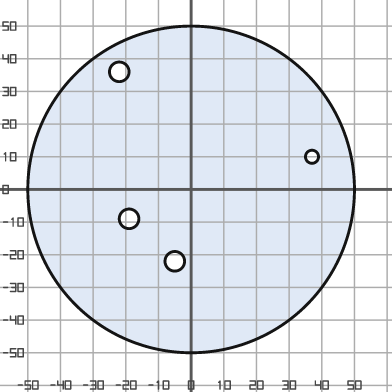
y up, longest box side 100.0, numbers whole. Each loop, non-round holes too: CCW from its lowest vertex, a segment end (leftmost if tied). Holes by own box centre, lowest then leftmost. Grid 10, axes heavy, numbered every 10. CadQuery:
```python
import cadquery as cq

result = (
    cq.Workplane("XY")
    .moveTo(0.0, 0.0)
    .circle(50.0)
    .moveTo(-5.0, -22.0)
    .circle(3.0)
    .moveTo(-19.0, -9.0)
    .circle(3.0)
    .moveTo(37.0, 10.0)
    .circle(2.0)
    .moveTo(-22.0, 36.0)
    .circle(3.0)
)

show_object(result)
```